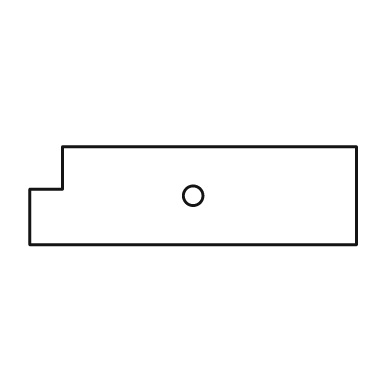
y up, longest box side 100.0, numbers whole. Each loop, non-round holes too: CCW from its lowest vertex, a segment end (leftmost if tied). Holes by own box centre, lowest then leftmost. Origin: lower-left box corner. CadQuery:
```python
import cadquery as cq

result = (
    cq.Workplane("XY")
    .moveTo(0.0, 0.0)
    .lineTo(100.0, 0.0)
    .lineTo(100.0, 30.0)
    .lineTo(10.0, 30.0)
    .lineTo(10.0, 17.0)
    .lineTo(0.0, 17.0)
    .close()
    .moveTo(50.0, 15.0)
    .circle(3.0)
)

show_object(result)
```